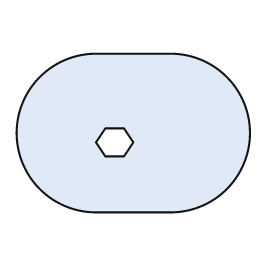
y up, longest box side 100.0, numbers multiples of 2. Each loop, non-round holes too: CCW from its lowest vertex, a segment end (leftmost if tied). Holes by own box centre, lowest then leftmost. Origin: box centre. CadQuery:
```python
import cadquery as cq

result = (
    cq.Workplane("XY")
    .moveTo(-16.0, -34.0)
    .lineTo(16.0, -34.0)
    .threePointArc((50.0, 0.0), (16.0, 34.0))
    .lineTo(-16.0, 34.0)
    .threePointArc((-50.0, 0.0), (-16.0, -34.0))
    .close()
    .moveTo(-12.0, -10.0)
    .lineTo(-4.0, -10.0)
    .lineTo(0.0, -4.0)
    .lineTo(-4.0, 2.0)
    .lineTo(-12.0, 2.0)
    .lineTo(-16.0, -4.0)
    .close()
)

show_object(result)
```